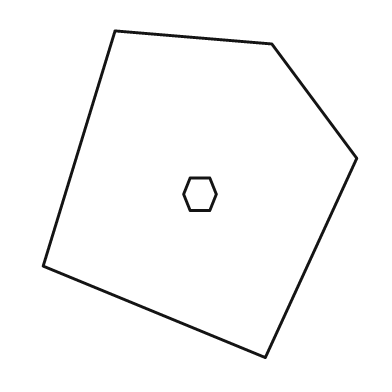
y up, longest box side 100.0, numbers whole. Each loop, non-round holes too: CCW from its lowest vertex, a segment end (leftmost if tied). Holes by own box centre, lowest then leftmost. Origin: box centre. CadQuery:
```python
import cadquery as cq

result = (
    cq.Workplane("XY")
    .moveTo(20.0, -50.0)
    .lineTo(48.0, 11.0)
    .lineTo(22.0, 46.0)
    .lineTo(-26.0, 50.0)
    .lineTo(-48.0, -22.0)
    .close()
    .moveTo(-3.0, -5.0)
    .lineTo(3.0, -5.0)
    .lineTo(5.0, 0.0)
    .lineTo(3.0, 5.0)
    .lineTo(-3.0, 5.0)
    .lineTo(-5.0, 0.0)
    .close()
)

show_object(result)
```